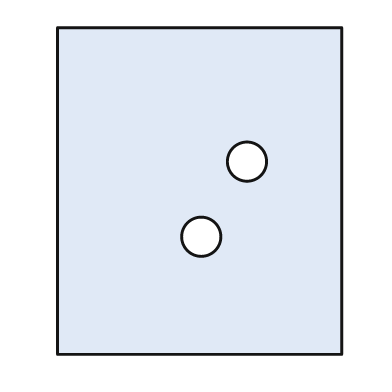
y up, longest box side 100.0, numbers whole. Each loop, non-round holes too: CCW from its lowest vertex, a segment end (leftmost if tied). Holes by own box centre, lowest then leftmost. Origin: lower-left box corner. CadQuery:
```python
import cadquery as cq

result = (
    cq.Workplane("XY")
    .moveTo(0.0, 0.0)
    .lineTo(87.0, 0.0)
    .lineTo(87.0, 100.0)
    .lineTo(0.0, 100.0)
    .close()
    .moveTo(44.0, 36.0)
    .circle(6.0)
    .moveTo(58.0, 59.0)
    .circle(6.0)
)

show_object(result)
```